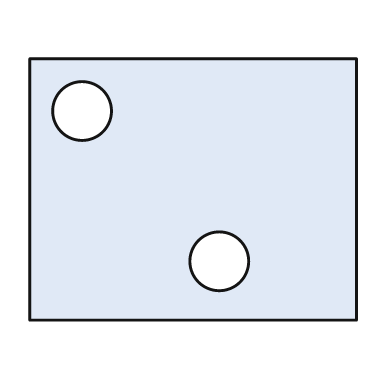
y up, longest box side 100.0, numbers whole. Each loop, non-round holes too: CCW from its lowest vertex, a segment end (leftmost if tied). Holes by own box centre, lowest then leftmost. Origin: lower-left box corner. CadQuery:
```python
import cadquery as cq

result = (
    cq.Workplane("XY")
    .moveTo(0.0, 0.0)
    .lineTo(100.0, 0.0)
    .lineTo(100.0, 80.0)
    .lineTo(0.0, 80.0)
    .close()
    .moveTo(58.0, 18.0)
    .circle(9.0)
    .moveTo(16.0, 64.0)
    .circle(9.0)
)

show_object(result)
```